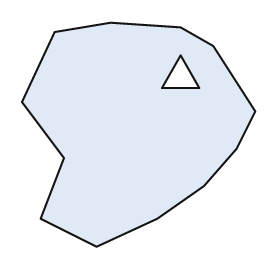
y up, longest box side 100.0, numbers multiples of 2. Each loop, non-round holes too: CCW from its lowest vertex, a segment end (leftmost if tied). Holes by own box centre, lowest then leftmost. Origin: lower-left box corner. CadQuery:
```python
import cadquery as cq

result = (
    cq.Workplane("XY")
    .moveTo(32.0, 0.0)
    .lineTo(58.0, 12.0)
    .lineTo(78.0, 26.0)
    .lineTo(92.0, 42.0)
    .lineTo(100.0, 58.0)
    .lineTo(82.0, 86.0)
    .lineTo(68.0, 94.0)
    .lineTo(38.0, 96.0)
    .lineTo(14.0, 92.0)
    .lineTo(0.0, 62.0)
    .lineTo(18.0, 38.0)
    .lineTo(8.0, 12.0)
    .close()
    .moveTo(60.0, 68.0)
    .lineTo(76.0, 68.0)
    .lineTo(68.0, 82.0)
    .close()
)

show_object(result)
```